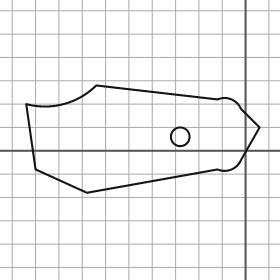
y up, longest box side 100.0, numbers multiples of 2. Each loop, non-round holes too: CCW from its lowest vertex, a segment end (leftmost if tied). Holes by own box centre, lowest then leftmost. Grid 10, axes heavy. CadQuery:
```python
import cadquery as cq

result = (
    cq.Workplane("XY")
    .moveTo(-68.0, -18.0)
    .lineTo(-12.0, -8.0)
    .threePointArc((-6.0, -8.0), (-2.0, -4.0))
    .lineTo(6.0, 10.0)
    .lineTo(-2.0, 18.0)
    .threePointArc((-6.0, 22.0), (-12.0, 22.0))
    .lineTo(-64.0, 28.0)
    .threePointArc((-78.0, 20.0), (-94.0, 20.0))
    .lineTo(-90.0, -8.0)
    .close()
    .moveTo(-28.0, 6.0)
    .circle(4.0)
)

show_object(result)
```